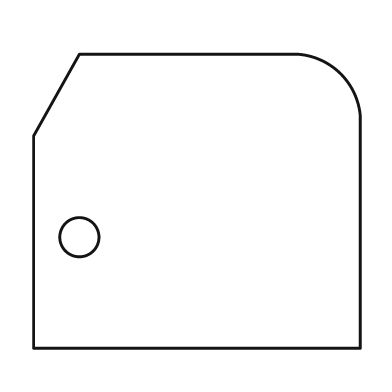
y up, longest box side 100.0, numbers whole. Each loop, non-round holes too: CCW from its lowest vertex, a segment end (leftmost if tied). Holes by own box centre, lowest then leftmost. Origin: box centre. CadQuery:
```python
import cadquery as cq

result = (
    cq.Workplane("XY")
    .moveTo(-50.0, -45.0)
    .lineTo(50.0, -45.0)
    .lineTo(50.0, 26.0)
    .threePointArc((44.0, 39.0), (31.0, 45.0))
    .lineTo(-36.0, 45.0)
    .lineTo(-50.0, 20.0)
    .close()
    .moveTo(-36.0, -11.0)
    .circle(6.0)
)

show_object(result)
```